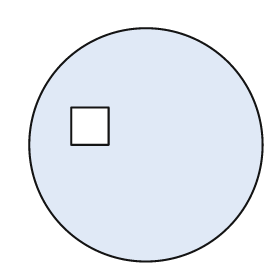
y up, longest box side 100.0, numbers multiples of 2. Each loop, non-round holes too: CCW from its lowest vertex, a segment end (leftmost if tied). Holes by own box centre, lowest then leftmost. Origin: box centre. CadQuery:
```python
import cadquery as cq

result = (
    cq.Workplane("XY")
    .moveTo(0.0, 0.0)
    .circle(50.0)
    .moveTo(-32.0, 0.0)
    .lineTo(-16.0, 0.0)
    .lineTo(-16.0, 16.0)
    .lineTo(-32.0, 16.0)
    .close()
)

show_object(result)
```